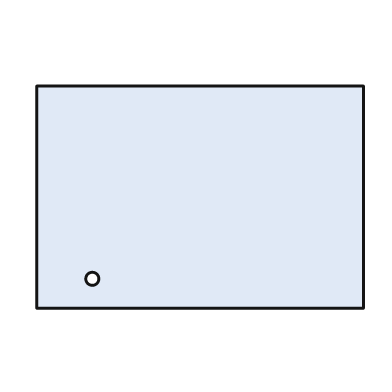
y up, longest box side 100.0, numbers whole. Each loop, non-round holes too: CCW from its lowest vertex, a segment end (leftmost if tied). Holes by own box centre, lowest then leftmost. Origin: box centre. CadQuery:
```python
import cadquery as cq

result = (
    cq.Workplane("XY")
    .moveTo(-50.0, -34.0)
    .lineTo(50.0, -34.0)
    .lineTo(50.0, 34.0)
    .lineTo(-50.0, 34.0)
    .close()
    .moveTo(-33.0, -25.0)
    .circle(2.0)
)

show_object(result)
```